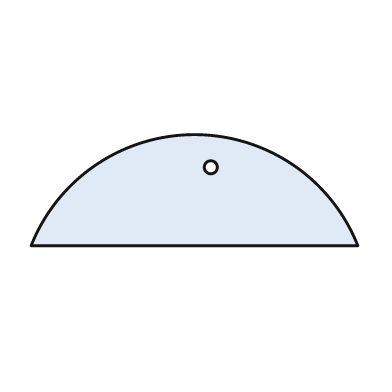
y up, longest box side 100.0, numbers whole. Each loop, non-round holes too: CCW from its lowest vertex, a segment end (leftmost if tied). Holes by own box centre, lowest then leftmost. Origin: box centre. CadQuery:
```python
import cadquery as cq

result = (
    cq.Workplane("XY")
    .moveTo(-50.0, -17.0)
    .lineTo(50.0, -17.0)
    .threePointArc((0.0, 17.0), (-50.0, -17.0))
    .close()
    .moveTo(5.0, 7.0)
    .circle(2.0)
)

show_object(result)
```